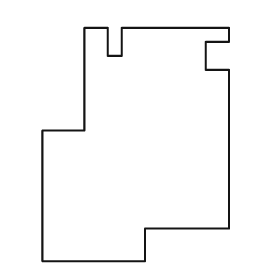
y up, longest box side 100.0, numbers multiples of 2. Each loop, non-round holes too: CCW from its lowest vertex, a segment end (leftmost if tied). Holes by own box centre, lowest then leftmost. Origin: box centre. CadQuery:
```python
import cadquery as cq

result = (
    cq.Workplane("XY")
    .moveTo(-40.0, -50.0)
    .lineTo(4.0, -50.0)
    .lineTo(4.0, -36.0)
    .lineTo(40.0, -36.0)
    .lineTo(40.0, 32.0)
    .lineTo(30.0, 32.0)
    .lineTo(30.0, 44.0)
    .lineTo(40.0, 44.0)
    .lineTo(40.0, 50.0)
    .lineTo(-6.0, 50.0)
    .lineTo(-6.0, 38.0)
    .lineTo(-12.0, 38.0)
    .lineTo(-12.0, 50.0)
    .lineTo(-22.0, 50.0)
    .lineTo(-22.0, 6.0)
    .lineTo(-40.0, 6.0)
    .close()
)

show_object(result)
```